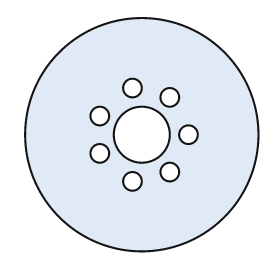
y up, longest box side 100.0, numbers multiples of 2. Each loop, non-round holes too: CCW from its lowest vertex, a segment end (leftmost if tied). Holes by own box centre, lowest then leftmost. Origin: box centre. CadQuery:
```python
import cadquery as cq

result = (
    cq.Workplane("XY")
    .moveTo(0.0, 0.0)
    .circle(50.0)
    .moveTo(-4.0, -20.0)
    .circle(4.0)
    .moveTo(12.0, -16.0)
    .circle(4.0)
    .moveTo(-18.0, -8.0)
    .circle(4.0)
    .moveTo(0.0, 0.0)
    .circle(12.0)
    .moveTo(20.0, 0.0)
    .circle(4.0)
    .moveTo(-18.0, 8.0)
    .circle(4.0)
    .moveTo(12.0, 16.0)
    .circle(4.0)
    .moveTo(-4.0, 20.0)
    .circle(4.0)
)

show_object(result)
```